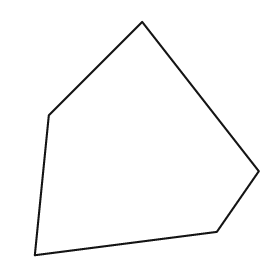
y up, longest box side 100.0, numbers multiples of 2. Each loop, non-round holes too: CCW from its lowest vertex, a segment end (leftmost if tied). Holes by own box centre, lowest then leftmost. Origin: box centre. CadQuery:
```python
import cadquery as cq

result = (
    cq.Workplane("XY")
    .moveTo(-48.0, -50.0)
    .lineTo(30.0, -40.0)
    .lineTo(48.0, -14.0)
    .lineTo(-2.0, 50.0)
    .lineTo(-42.0, 10.0)
    .close()
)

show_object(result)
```